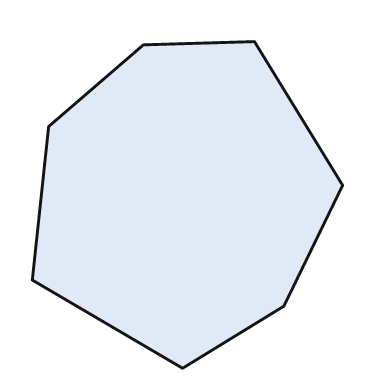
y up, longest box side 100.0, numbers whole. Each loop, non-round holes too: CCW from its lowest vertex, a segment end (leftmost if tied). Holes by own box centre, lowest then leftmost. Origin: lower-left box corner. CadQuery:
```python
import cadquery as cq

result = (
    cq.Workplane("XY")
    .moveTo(46.0, 0.0)
    .lineTo(77.0, 19.0)
    .lineTo(95.0, 56.0)
    .lineTo(68.0, 100.0)
    .lineTo(34.0, 99.0)
    .lineTo(5.0, 74.0)
    .lineTo(0.0, 27.0)
    .close()
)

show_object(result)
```